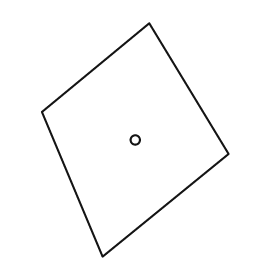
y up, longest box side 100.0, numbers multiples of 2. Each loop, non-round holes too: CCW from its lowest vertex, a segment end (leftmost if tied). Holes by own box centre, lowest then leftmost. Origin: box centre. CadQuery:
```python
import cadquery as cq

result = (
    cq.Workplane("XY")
    .moveTo(-14.0, -50.0)
    .lineTo(40.0, -6.0)
    .lineTo(6.0, 50.0)
    .lineTo(-40.0, 12.0)
    .close()
    .moveTo(0.0, 0.0)
    .circle(2.0)
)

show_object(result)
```